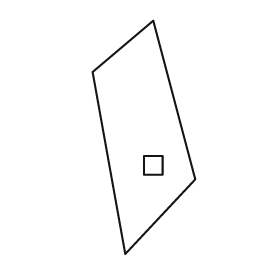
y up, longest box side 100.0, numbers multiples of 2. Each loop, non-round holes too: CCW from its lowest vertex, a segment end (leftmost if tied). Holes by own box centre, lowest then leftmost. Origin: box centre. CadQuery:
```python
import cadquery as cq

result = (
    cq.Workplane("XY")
    .moveTo(-8.0, -50.0)
    .lineTo(22.0, -18.0)
    .lineTo(4.0, 50.0)
    .lineTo(-22.0, 28.0)
    .close()
    .moveTo(0.0, -16.0)
    .lineTo(8.0, -16.0)
    .lineTo(8.0, -8.0)
    .lineTo(0.0, -8.0)
    .close()
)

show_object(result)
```